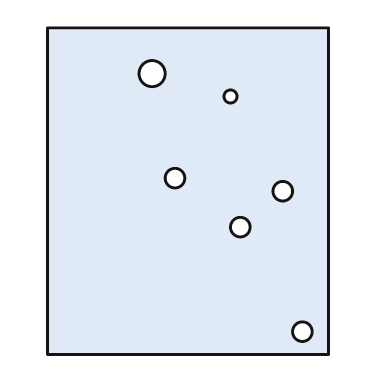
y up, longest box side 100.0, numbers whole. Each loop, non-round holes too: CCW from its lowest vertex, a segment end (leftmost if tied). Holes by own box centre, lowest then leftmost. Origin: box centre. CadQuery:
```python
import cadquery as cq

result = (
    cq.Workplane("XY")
    .moveTo(-43.0, -50.0)
    .lineTo(43.0, -50.0)
    .lineTo(43.0, 50.0)
    .lineTo(-43.0, 50.0)
    .close()
    .moveTo(35.0, -43.0)
    .circle(3.0)
    .moveTo(16.0, -11.0)
    .circle(3.0)
    .moveTo(29.0, 0.0)
    .circle(3.0)
    .moveTo(-4.0, 4.0)
    .circle(3.0)
    .moveTo(13.0, 29.0)
    .circle(2.0)
    .moveTo(-11.0, 36.0)
    .circle(4.0)
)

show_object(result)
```